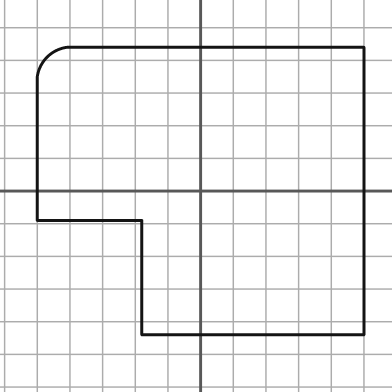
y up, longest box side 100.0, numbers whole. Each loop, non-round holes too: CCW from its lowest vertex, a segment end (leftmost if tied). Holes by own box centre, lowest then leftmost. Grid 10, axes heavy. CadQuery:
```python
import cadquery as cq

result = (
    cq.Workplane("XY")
    .moveTo(-18.0, -44.0)
    .lineTo(50.0, -44.0)
    .lineTo(50.0, 44.0)
    .lineTo(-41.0, 44.0)
    .threePointArc((-47.0, 41.0), (-50.0, 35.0))
    .lineTo(-50.0, -9.0)
    .lineTo(-18.0, -9.0)
    .close()
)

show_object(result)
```